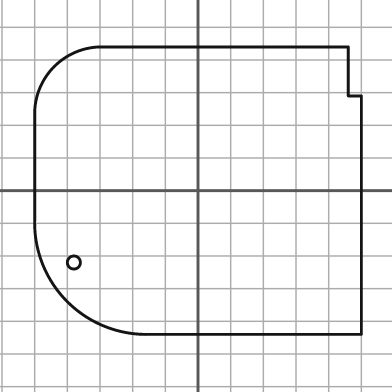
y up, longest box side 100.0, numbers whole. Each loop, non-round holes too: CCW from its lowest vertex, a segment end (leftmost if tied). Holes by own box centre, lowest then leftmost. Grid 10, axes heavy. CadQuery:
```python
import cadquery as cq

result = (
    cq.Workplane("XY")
    .moveTo(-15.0, -44.0)
    .lineTo(50.0, -44.0)
    .lineTo(50.0, 29.0)
    .lineTo(46.0, 29.0)
    .lineTo(46.0, 44.0)
    .lineTo(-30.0, 44.0)
    .threePointArc((-44.0, 38.0), (-50.0, 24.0))
    .lineTo(-50.0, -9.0)
    .threePointArc((-40.0, -34.0), (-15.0, -44.0))
    .close()
    .moveTo(-38.0, -22.0)
    .circle(2.0)
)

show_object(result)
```